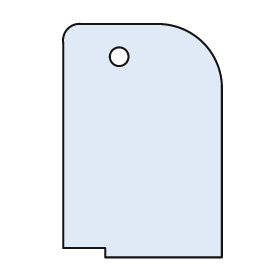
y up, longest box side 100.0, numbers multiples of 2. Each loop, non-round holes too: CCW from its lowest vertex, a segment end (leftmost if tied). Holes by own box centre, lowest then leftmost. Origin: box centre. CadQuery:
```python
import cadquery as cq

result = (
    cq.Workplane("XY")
    .moveTo(-16.0, -50.0)
    .lineTo(34.0, -50.0)
    .lineTo(34.0, 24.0)
    .threePointArc((26.0, 42.0), (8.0, 50.0))
    .lineTo(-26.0, 50.0)
    .threePointArc((-32.0, 48.0), (-34.0, 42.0))
    .lineTo(-34.0, -46.0)
    .lineTo(-16.0, -46.0)
    .close()
    .moveTo(-10.0, 36.0)
    .circle(4.0)
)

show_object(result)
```